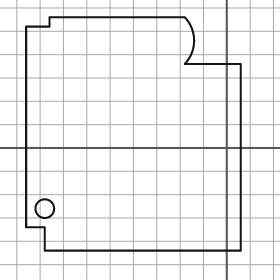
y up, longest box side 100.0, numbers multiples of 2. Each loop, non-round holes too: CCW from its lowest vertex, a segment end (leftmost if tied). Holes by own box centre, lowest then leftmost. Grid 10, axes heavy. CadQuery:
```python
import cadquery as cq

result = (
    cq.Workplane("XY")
    .moveTo(-78.0, -44.0)
    .lineTo(6.0, -44.0)
    .lineTo(6.0, 36.0)
    .lineTo(-18.0, 36.0)
    .threePointArc((-14.0, 46.0), (-18.0, 56.0))
    .lineTo(-76.0, 56.0)
    .lineTo(-76.0, 52.0)
    .lineTo(-86.0, 52.0)
    .lineTo(-86.0, -34.0)
    .lineTo(-78.0, -34.0)
    .close()
    .moveTo(-78.0, -26.0)
    .circle(4.0)
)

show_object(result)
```